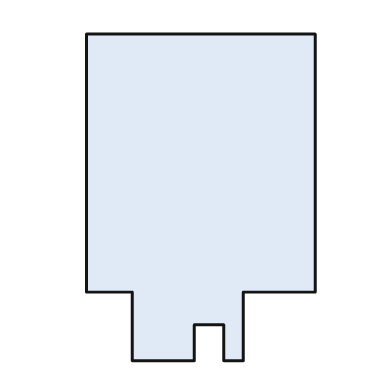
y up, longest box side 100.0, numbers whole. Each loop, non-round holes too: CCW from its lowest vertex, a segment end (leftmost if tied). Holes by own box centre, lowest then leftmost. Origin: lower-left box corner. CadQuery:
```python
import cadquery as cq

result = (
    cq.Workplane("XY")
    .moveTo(14.0, 0.0)
    .lineTo(33.0, 0.0)
    .lineTo(33.0, 11.0)
    .lineTo(42.0, 11.0)
    .lineTo(42.0, 0.0)
    .lineTo(48.0, 0.0)
    .lineTo(48.0, 21.0)
    .lineTo(70.0, 21.0)
    .lineTo(70.0, 100.0)
    .lineTo(0.0, 100.0)
    .lineTo(0.0, 21.0)
    .lineTo(14.0, 21.0)
    .close()
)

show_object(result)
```